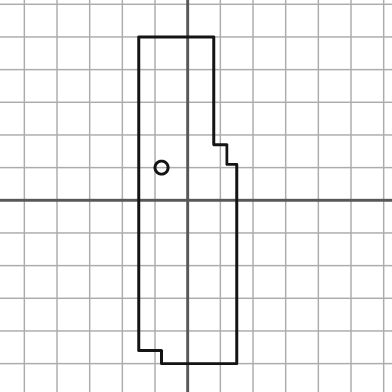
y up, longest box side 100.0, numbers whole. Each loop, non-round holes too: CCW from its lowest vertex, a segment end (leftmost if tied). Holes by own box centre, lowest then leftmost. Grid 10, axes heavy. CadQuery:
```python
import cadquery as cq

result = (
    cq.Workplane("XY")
    .moveTo(-8.0, -50.0)
    .lineTo(15.0, -50.0)
    .lineTo(15.0, 11.0)
    .lineTo(12.0, 11.0)
    .lineTo(12.0, 17.0)
    .lineTo(8.0, 17.0)
    .lineTo(8.0, 50.0)
    .lineTo(-15.0, 50.0)
    .lineTo(-15.0, -46.0)
    .lineTo(-8.0, -46.0)
    .close()
    .moveTo(-8.0, 10.0)
    .circle(2.0)
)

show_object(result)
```